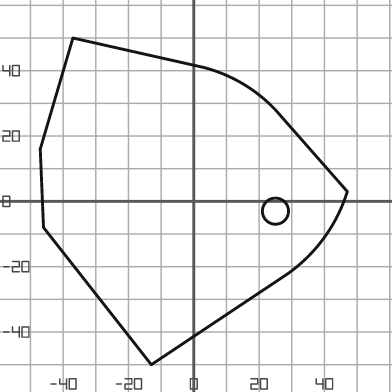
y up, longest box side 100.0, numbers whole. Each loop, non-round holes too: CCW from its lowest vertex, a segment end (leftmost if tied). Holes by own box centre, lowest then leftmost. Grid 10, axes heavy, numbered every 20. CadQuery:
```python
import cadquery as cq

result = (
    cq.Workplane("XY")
    .moveTo(-13.0, -50.0)
    .lineTo(29.0, -22.0)
    .threePointArc((40.0, -11.0), (47.0, 3.0))
    .lineTo(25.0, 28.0)
    .threePointArc((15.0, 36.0), (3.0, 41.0))
    .lineTo(-37.0, 50.0)
    .lineTo(-47.0, 16.0)
    .lineTo(-46.0, -8.0)
    .close()
    .moveTo(25.0, -3.0)
    .circle(4.0)
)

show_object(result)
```